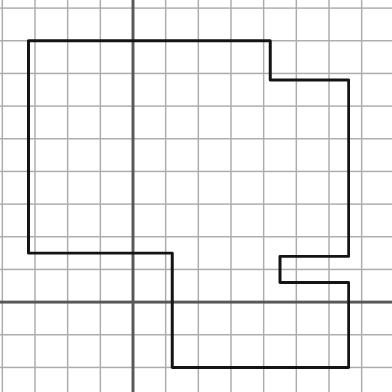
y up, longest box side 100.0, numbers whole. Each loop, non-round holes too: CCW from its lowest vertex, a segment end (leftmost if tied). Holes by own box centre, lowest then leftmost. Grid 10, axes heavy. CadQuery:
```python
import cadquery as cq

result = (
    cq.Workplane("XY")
    .moveTo(12.0, -20.0)
    .lineTo(66.0, -20.0)
    .lineTo(66.0, 6.0)
    .lineTo(45.0, 6.0)
    .lineTo(45.0, 14.0)
    .lineTo(66.0, 14.0)
    .lineTo(66.0, 68.0)
    .lineTo(42.0, 68.0)
    .lineTo(42.0, 80.0)
    .lineTo(-32.0, 80.0)
    .lineTo(-32.0, 15.0)
    .lineTo(12.0, 15.0)
    .close()
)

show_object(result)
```